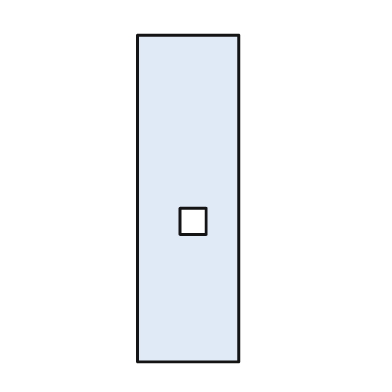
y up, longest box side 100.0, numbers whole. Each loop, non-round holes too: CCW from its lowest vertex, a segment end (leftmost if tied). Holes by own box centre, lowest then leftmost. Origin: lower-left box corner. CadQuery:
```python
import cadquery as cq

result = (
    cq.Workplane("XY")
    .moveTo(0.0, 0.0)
    .lineTo(31.0, 0.0)
    .lineTo(31.0, 100.0)
    .lineTo(0.0, 100.0)
    .close()
    .moveTo(13.0, 39.0)
    .lineTo(21.0, 39.0)
    .lineTo(21.0, 47.0)
    .lineTo(13.0, 47.0)
    .close()
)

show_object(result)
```